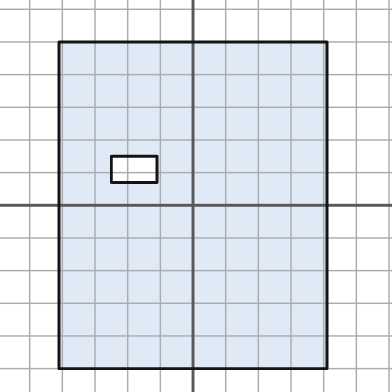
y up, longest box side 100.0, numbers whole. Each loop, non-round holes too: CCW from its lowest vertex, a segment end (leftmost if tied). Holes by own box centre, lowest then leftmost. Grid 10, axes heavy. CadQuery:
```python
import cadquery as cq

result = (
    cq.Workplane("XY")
    .moveTo(-41.0, -50.0)
    .lineTo(41.0, -50.0)
    .lineTo(41.0, 50.0)
    .lineTo(-41.0, 50.0)
    .close()
    .moveTo(-25.0, 7.0)
    .lineTo(-11.0, 7.0)
    .lineTo(-11.0, 15.0)
    .lineTo(-25.0, 15.0)
    .close()
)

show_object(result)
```